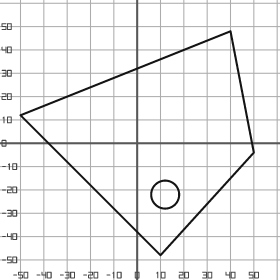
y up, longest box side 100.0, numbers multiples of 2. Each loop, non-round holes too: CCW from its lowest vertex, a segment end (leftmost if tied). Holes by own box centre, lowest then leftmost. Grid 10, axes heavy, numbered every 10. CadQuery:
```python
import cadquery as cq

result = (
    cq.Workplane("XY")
    .moveTo(10.0, -48.0)
    .lineTo(50.0, -4.0)
    .lineTo(40.0, 48.0)
    .lineTo(-50.0, 12.0)
    .close()
    .moveTo(12.0, -22.0)
    .circle(6.0)
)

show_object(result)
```